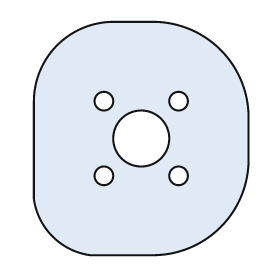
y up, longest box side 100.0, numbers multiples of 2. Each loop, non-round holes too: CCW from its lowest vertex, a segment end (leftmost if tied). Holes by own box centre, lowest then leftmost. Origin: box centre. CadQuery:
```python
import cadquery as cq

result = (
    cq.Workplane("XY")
    .moveTo(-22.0, -50.0)
    .lineTo(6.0, -50.0)
    .threePointArc((34.0, -38.0), (46.0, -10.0))
    .lineTo(46.0, 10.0)
    .threePointArc((34.0, 38.0), (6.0, 50.0))
    .lineTo(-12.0, 50.0)
    .threePointArc((-36.0, 40.0), (-46.0, 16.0))
    .lineTo(-46.0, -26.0)
    .threePointArc((-38.0, -42.0), (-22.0, -50.0))
    .close()
    .moveTo(-16.0, -16.0)
    .circle(4.0)
    .moveTo(16.0, -16.0)
    .circle(4.0)
    .moveTo(0.0, 0.0)
    .circle(12.0)
    .moveTo(-16.0, 16.0)
    .circle(4.0)
    .moveTo(16.0, 16.0)
    .circle(4.0)
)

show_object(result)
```